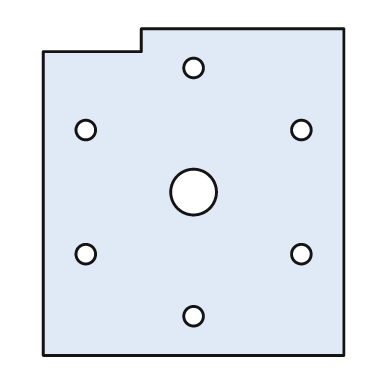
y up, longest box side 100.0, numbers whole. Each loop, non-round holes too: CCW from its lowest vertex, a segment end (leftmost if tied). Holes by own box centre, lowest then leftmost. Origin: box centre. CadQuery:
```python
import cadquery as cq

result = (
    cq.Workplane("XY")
    .moveTo(-46.0, -50.0)
    .lineTo(46.0, -50.0)
    .lineTo(46.0, 50.0)
    .lineTo(-16.0, 50.0)
    .lineTo(-16.0, 43.0)
    .lineTo(-46.0, 43.0)
    .close()
    .moveTo(0.0, -38.0)
    .circle(3.0)
    .moveTo(-33.0, -19.0)
    .circle(3.0)
    .moveTo(33.0, -19.0)
    .circle(3.0)
    .moveTo(0.0, 0.0)
    .circle(7.0)
    .moveTo(-33.0, 19.0)
    .circle(3.0)
    .moveTo(33.0, 19.0)
    .circle(3.0)
    .moveTo(0.0, 38.0)
    .circle(3.0)
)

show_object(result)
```